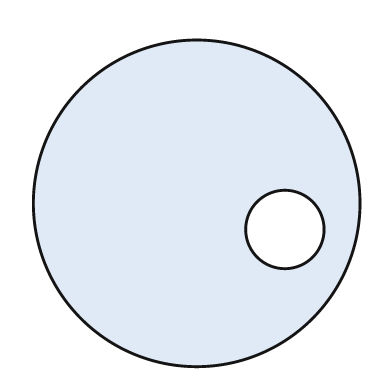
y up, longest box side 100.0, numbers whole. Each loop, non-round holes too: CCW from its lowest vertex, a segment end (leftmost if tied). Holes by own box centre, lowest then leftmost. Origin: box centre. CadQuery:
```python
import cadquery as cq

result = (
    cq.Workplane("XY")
    .moveTo(0.0, 0.0)
    .circle(50.0)
    .moveTo(27.0, -8.0)
    .circle(12.0)
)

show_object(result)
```